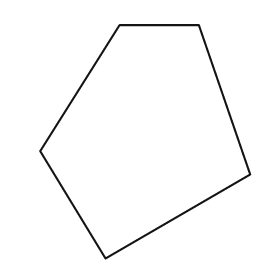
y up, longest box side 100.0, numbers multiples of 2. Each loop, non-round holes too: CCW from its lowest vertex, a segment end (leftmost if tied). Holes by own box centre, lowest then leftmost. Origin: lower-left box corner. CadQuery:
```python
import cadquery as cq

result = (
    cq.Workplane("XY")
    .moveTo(28.0, 0.0)
    .lineTo(90.0, 36.0)
    .lineTo(68.0, 100.0)
    .lineTo(34.0, 100.0)
    .lineTo(0.0, 46.0)
    .close()
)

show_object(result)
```